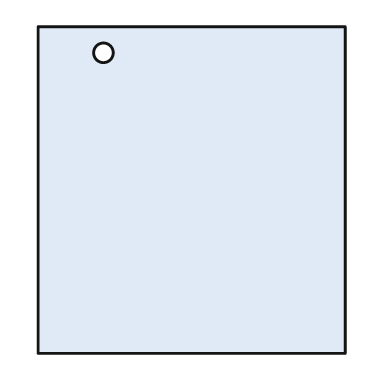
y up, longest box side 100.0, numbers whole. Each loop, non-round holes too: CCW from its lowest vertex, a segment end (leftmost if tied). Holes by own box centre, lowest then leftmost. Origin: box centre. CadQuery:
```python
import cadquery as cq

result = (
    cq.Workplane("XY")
    .moveTo(-47.0, -50.0)
    .lineTo(47.0, -50.0)
    .lineTo(47.0, 50.0)
    .lineTo(-47.0, 50.0)
    .close()
    .moveTo(-27.0, 42.0)
    .circle(3.0)
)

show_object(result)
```